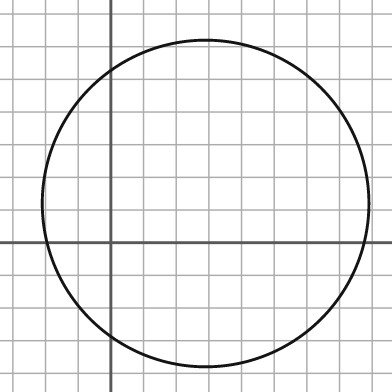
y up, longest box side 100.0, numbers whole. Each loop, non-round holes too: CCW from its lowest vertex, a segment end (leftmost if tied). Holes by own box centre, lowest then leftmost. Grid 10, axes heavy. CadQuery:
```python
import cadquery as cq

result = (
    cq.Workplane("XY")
    .moveTo(29.0, 12.0)
    .circle(50.0)
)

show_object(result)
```